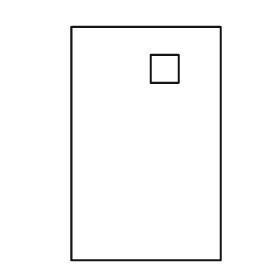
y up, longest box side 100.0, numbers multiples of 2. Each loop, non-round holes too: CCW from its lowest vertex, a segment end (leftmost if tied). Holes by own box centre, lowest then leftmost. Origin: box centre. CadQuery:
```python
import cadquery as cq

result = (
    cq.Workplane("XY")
    .moveTo(-32.0, -50.0)
    .lineTo(32.0, -50.0)
    .lineTo(32.0, 50.0)
    .lineTo(-32.0, 50.0)
    .close()
    .moveTo(2.0, 26.0)
    .lineTo(14.0, 26.0)
    .lineTo(14.0, 38.0)
    .lineTo(2.0, 38.0)
    .close()
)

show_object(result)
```